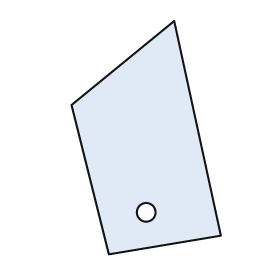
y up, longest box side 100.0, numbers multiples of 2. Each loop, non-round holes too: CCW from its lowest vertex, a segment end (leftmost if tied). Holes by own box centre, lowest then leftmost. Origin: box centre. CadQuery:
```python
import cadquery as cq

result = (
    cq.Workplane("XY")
    .moveTo(-16.0, -50.0)
    .lineTo(32.0, -42.0)
    .lineTo(12.0, 50.0)
    .lineTo(-32.0, 14.0)
    .close()
    .moveTo(0.0, -32.0)
    .circle(4.0)
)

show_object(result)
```